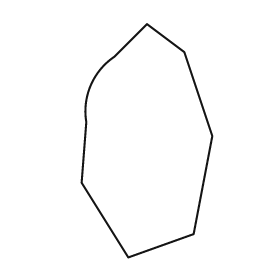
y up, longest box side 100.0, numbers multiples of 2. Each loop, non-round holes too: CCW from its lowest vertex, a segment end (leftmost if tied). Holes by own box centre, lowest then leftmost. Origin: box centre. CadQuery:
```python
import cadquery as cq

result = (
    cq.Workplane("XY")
    .moveTo(-8.0, -50.0)
    .lineTo(20.0, -40.0)
    .lineTo(28.0, 2.0)
    .lineTo(16.0, 38.0)
    .lineTo(0.0, 50.0)
    .lineTo(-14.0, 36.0)
    .threePointArc((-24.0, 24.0), (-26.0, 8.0))
    .lineTo(-28.0, -18.0)
    .close()
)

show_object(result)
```